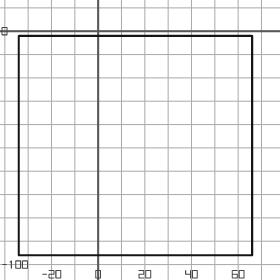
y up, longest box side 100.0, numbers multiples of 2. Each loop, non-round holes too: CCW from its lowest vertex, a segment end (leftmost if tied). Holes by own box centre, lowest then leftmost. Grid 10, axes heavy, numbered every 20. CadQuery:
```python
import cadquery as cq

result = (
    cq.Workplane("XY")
    .moveTo(-34.0, -96.0)
    .lineTo(66.0, -96.0)
    .lineTo(66.0, -2.0)
    .lineTo(-34.0, -2.0)
    .close()
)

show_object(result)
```